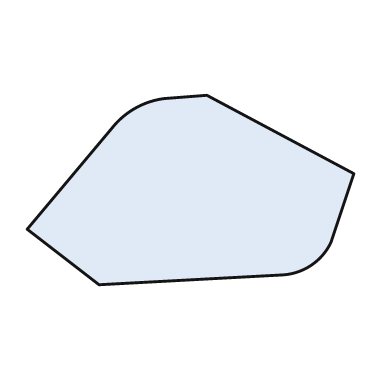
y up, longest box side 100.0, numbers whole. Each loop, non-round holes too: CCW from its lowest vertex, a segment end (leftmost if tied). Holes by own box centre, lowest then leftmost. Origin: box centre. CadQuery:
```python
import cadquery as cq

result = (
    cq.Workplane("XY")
    .moveTo(-28.0, -29.0)
    .lineTo(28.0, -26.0)
    .threePointArc((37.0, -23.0), (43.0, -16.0))
    .lineTo(50.0, 5.0)
    .lineTo(5.0, 29.0)
    .lineTo(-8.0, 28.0)
    .threePointArc((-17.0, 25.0), (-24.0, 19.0))
    .lineTo(-50.0, -12.0)
    .close()
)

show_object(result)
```